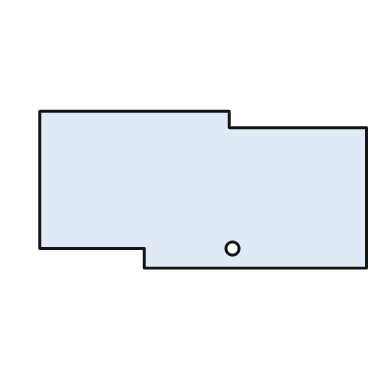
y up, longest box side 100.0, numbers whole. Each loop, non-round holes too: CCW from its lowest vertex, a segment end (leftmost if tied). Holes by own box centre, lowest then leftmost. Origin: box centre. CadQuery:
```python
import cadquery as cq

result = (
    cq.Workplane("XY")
    .moveTo(-18.0, -24.0)
    .lineTo(50.0, -24.0)
    .lineTo(50.0, 19.0)
    .lineTo(8.0, 19.0)
    .lineTo(8.0, 24.0)
    .lineTo(-50.0, 24.0)
    .lineTo(-50.0, -18.0)
    .lineTo(-18.0, -18.0)
    .close()
    .moveTo(9.0, -18.0)
    .circle(2.0)
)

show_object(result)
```